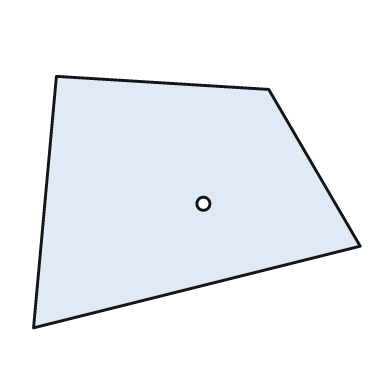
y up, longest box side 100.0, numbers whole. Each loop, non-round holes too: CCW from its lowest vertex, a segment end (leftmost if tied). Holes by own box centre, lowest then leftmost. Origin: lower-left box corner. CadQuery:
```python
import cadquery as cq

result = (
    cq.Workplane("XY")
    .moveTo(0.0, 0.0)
    .lineTo(100.0, 25.0)
    .lineTo(72.0, 73.0)
    .lineTo(7.0, 77.0)
    .close()
    .moveTo(52.0, 38.0)
    .circle(2.0)
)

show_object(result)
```